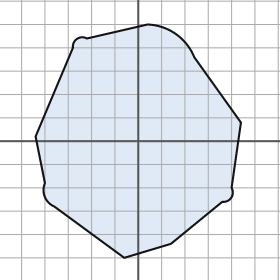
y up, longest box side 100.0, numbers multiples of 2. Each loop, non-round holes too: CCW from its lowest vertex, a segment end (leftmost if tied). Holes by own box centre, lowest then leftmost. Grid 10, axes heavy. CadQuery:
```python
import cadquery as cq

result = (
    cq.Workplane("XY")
    .moveTo(-6.0, -50.0)
    .lineTo(14.0, -44.0)
    .lineTo(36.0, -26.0)
    .threePointArc((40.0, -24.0), (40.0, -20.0))
    .lineTo(44.0, 8.0)
    .lineTo(24.0, 36.0)
    .threePointArc((16.0, 46.0), (4.0, 50.0))
    .lineTo(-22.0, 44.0)
    .threePointArc((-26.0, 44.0), (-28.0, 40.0))
    .lineTo(-44.0, 2.0)
    .lineTo(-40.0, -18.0)
    .threePointArc((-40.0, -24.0), (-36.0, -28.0))
    .close()
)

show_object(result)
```